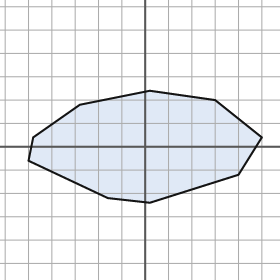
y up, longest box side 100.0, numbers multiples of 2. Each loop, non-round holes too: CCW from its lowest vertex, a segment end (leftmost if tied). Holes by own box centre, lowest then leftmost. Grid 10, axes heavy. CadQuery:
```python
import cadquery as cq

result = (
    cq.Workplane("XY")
    .moveTo(2.0, -24.0)
    .lineTo(40.0, -12.0)
    .lineTo(50.0, 4.0)
    .lineTo(30.0, 20.0)
    .lineTo(2.0, 24.0)
    .lineTo(-28.0, 18.0)
    .lineTo(-48.0, 4.0)
    .lineTo(-50.0, -6.0)
    .lineTo(-16.0, -22.0)
    .close()
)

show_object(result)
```